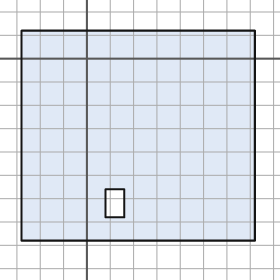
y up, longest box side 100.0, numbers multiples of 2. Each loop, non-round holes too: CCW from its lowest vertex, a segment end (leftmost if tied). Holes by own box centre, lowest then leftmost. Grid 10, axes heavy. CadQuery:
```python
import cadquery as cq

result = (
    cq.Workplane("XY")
    .moveTo(-28.0, -78.0)
    .lineTo(72.0, -78.0)
    .lineTo(72.0, 12.0)
    .lineTo(-28.0, 12.0)
    .close()
    .moveTo(8.0, -68.0)
    .lineTo(16.0, -68.0)
    .lineTo(16.0, -56.0)
    .lineTo(8.0, -56.0)
    .close()
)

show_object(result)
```